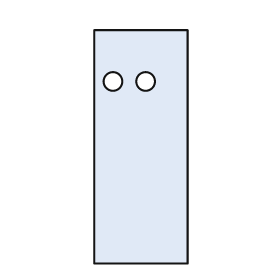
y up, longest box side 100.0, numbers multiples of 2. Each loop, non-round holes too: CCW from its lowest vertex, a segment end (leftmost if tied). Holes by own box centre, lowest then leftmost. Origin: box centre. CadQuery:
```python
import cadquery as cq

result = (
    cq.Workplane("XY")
    .moveTo(-20.0, -50.0)
    .lineTo(20.0, -50.0)
    .lineTo(20.0, 50.0)
    .lineTo(-20.0, 50.0)
    .close()
    .moveTo(-12.0, 28.0)
    .circle(4.0)
    .moveTo(2.0, 28.0)
    .circle(4.0)
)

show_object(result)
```